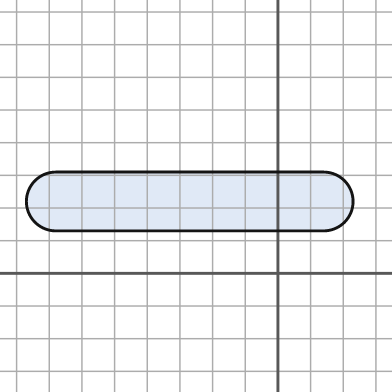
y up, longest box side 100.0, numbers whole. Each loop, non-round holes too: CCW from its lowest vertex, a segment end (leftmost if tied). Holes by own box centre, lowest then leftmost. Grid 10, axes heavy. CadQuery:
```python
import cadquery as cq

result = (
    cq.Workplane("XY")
    .moveTo(-68.0, 13.0)
    .lineTo(14.0, 13.0)
    .threePointArc((23.0, 22.0), (14.0, 31.0))
    .lineTo(-68.0, 31.0)
    .threePointArc((-77.0, 22.0), (-68.0, 13.0))
    .close()
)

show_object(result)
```